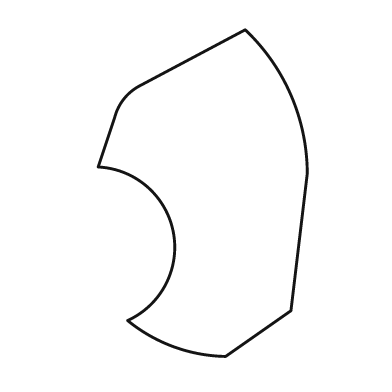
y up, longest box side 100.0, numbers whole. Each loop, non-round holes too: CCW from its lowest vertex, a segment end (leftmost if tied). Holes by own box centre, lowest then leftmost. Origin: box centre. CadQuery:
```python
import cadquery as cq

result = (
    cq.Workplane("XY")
    .moveTo(7.0, -50.0)
    .lineTo(27.0, -36.0)
    .lineTo(32.0, 6.0)
    .threePointArc((27.0, 30.0), (13.0, 50.0))
    .lineTo(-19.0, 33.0)
    .threePointArc((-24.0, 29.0), (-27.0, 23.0))
    .lineTo(-32.0, 8.0)
    .threePointArc((-9.0, -12.0), (-23.0, -39.0))
    .threePointArc((-9.0, -47.0), (7.0, -50.0))
    .close()
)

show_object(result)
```